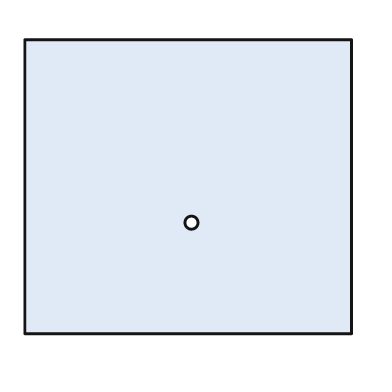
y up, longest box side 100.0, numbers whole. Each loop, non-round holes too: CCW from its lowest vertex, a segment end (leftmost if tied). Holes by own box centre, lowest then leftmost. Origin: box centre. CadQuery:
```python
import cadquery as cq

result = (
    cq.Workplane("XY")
    .moveTo(-50.0, -45.0)
    .lineTo(50.0, -45.0)
    .lineTo(50.0, 45.0)
    .lineTo(-50.0, 45.0)
    .close()
    .moveTo(1.0, -11.0)
    .circle(2.0)
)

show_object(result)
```